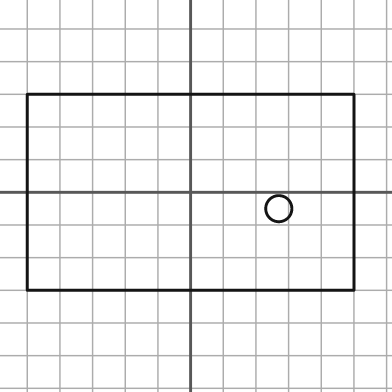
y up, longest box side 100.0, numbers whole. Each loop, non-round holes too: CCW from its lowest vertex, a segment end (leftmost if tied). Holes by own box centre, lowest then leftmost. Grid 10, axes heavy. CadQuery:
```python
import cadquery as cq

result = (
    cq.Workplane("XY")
    .moveTo(-50.0, -30.0)
    .lineTo(50.0, -30.0)
    .lineTo(50.0, 30.0)
    .lineTo(-50.0, 30.0)
    .close()
    .moveTo(27.0, -5.0)
    .circle(4.0)
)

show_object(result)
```